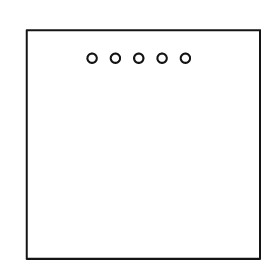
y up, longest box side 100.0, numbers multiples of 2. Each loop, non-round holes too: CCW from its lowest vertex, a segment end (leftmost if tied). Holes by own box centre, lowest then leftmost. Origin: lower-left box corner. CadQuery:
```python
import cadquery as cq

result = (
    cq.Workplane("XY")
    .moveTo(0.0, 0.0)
    .lineTo(100.0, 0.0)
    .lineTo(100.0, 98.0)
    .lineTo(0.0, 98.0)
    .close()
    .moveTo(28.0, 86.0)
    .circle(2.0)
    .moveTo(38.0, 86.0)
    .circle(2.0)
    .moveTo(48.0, 86.0)
    .circle(2.0)
    .moveTo(58.0, 86.0)
    .circle(2.0)
    .moveTo(68.0, 86.0)
    .circle(2.0)
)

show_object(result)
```